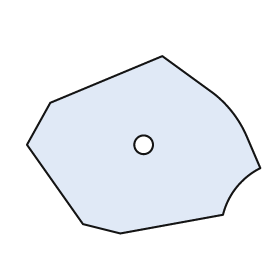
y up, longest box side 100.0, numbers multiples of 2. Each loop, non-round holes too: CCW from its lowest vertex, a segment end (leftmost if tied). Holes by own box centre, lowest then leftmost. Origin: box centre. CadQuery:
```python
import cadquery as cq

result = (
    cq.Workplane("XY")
    .moveTo(-10.0, -38.0)
    .lineTo(34.0, -30.0)
    .threePointArc((40.0, -18.0), (50.0, -10.0))
    .lineTo(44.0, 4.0)
    .threePointArc((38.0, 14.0), (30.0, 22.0))
    .lineTo(8.0, 38.0)
    .lineTo(-40.0, 18.0)
    .lineTo(-50.0, 0.0)
    .lineTo(-26.0, -34.0)
    .close()
    .moveTo(0.0, 0.0)
    .circle(4.0)
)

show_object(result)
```